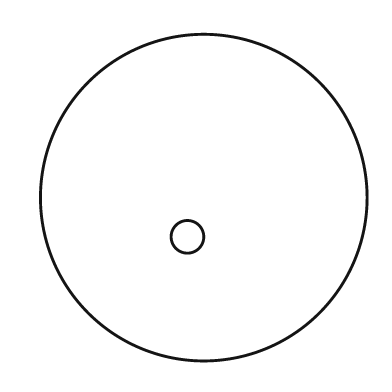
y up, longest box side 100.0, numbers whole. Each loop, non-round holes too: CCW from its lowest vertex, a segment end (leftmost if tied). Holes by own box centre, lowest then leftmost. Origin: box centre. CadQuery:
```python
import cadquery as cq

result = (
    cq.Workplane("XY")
    .moveTo(0.0, 0.0)
    .circle(50.0)
    .moveTo(-5.0, -12.0)
    .circle(5.0)
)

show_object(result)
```